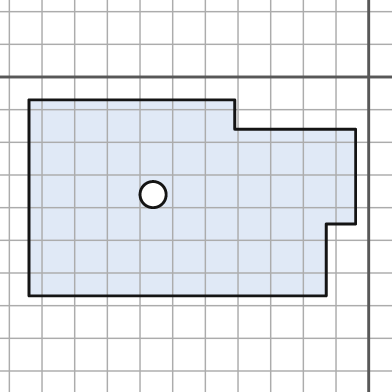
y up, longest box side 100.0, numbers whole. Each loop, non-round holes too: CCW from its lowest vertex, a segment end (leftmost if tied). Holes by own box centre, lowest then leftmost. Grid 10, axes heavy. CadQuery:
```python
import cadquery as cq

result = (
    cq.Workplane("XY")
    .moveTo(-104.0, -67.0)
    .lineTo(-13.0, -67.0)
    .lineTo(-13.0, -45.0)
    .lineTo(-4.0, -45.0)
    .lineTo(-4.0, -16.0)
    .lineTo(-41.0, -16.0)
    .lineTo(-41.0, -7.0)
    .lineTo(-104.0, -7.0)
    .close()
    .moveTo(-66.0, -36.0)
    .circle(4.0)
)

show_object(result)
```